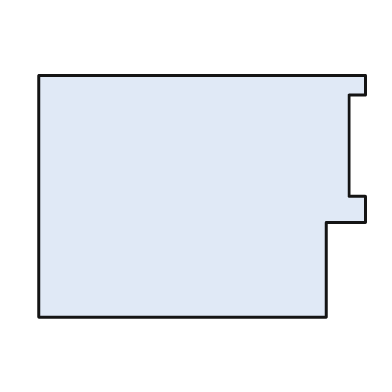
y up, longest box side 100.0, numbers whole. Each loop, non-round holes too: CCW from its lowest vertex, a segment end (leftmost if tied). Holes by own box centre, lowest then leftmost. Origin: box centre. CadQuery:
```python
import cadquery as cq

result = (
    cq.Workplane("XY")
    .moveTo(-50.0, -37.0)
    .lineTo(38.0, -37.0)
    .lineTo(38.0, -8.0)
    .lineTo(50.0, -8.0)
    .lineTo(50.0, 0.0)
    .lineTo(45.0, 0.0)
    .lineTo(45.0, 31.0)
    .lineTo(50.0, 31.0)
    .lineTo(50.0, 37.0)
    .lineTo(-50.0, 37.0)
    .close()
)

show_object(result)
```